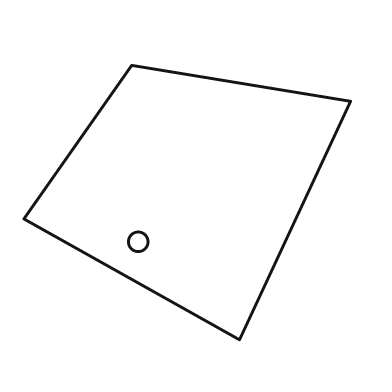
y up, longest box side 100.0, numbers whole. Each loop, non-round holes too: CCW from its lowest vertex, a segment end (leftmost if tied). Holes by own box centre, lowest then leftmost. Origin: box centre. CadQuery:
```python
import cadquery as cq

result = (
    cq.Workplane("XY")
    .moveTo(16.0, -42.0)
    .lineTo(50.0, 31.0)
    .lineTo(-17.0, 42.0)
    .lineTo(-50.0, -5.0)
    .close()
    .moveTo(-15.0, -12.0)
    .circle(3.0)
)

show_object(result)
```